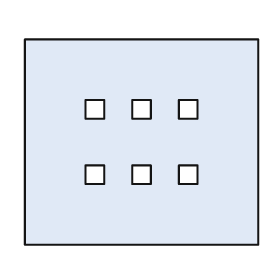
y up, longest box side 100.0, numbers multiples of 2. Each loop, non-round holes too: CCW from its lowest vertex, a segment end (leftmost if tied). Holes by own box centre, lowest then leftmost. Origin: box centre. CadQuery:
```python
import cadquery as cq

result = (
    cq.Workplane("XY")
    .moveTo(-50.0, -44.0)
    .lineTo(50.0, -44.0)
    .lineTo(50.0, 44.0)
    .lineTo(-50.0, 44.0)
    .close()
    .moveTo(-24.0, -18.0)
    .lineTo(-16.0, -18.0)
    .lineTo(-16.0, -10.0)
    .lineTo(-24.0, -10.0)
    .close()
    .moveTo(-4.0, -18.0)
    .lineTo(4.0, -18.0)
    .lineTo(4.0, -10.0)
    .lineTo(-4.0, -10.0)
    .close()
    .moveTo(16.0, -18.0)
    .lineTo(24.0, -18.0)
    .lineTo(24.0, -10.0)
    .lineTo(16.0, -10.0)
    .close()
    .moveTo(-24.0, 10.0)
    .lineTo(-16.0, 10.0)
    .lineTo(-16.0, 18.0)
    .lineTo(-24.0, 18.0)
    .close()
    .moveTo(-4.0, 10.0)
    .lineTo(4.0, 10.0)
    .lineTo(4.0, 18.0)
    .lineTo(-4.0, 18.0)
    .close()
    .moveTo(16.0, 10.0)
    .lineTo(24.0, 10.0)
    .lineTo(24.0, 18.0)
    .lineTo(16.0, 18.0)
    .close()
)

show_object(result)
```